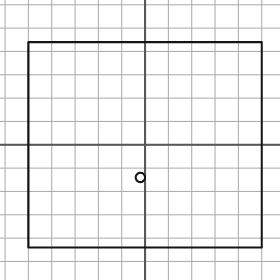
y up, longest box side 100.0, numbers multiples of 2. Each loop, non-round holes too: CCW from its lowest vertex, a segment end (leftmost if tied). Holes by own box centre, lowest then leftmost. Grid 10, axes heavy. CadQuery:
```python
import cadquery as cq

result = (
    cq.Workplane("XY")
    .moveTo(-50.0, -44.0)
    .lineTo(50.0, -44.0)
    .lineTo(50.0, 44.0)
    .lineTo(-50.0, 44.0)
    .close()
    .moveTo(-2.0, -14.0)
    .circle(2.0)
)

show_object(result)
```